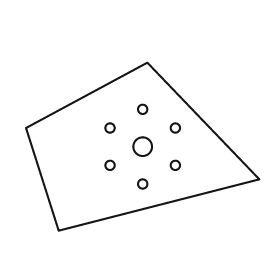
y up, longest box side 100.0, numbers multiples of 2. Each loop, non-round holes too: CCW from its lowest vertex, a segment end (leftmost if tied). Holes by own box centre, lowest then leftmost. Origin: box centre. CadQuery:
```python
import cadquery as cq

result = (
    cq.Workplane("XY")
    .moveTo(-36.0, -36.0)
    .lineTo(50.0, -14.0)
    .lineTo(2.0, 36.0)
    .lineTo(-50.0, 8.0)
    .close()
    .moveTo(0.0, -16.0)
    .circle(2.0)
    .moveTo(-14.0, -8.0)
    .circle(2.0)
    .moveTo(14.0, -8.0)
    .circle(2.0)
    .moveTo(0.0, 0.0)
    .circle(4.0)
    .moveTo(-14.0, 8.0)
    .circle(2.0)
    .moveTo(14.0, 8.0)
    .circle(2.0)
    .moveTo(0.0, 16.0)
    .circle(2.0)
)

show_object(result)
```